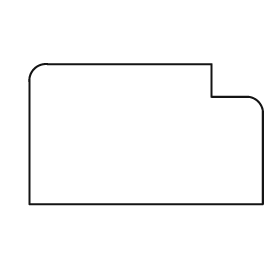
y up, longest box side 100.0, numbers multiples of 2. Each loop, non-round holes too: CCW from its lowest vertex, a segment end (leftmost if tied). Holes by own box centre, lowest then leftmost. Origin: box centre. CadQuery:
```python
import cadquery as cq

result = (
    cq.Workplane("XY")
    .moveTo(-50.0, -30.0)
    .lineTo(50.0, -30.0)
    .lineTo(50.0, 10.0)
    .threePointArc((48.0, 14.0), (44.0, 16.0))
    .lineTo(28.0, 16.0)
    .lineTo(28.0, 30.0)
    .lineTo(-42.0, 30.0)
    .threePointArc((-48.0, 28.0), (-50.0, 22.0))
    .close()
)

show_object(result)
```